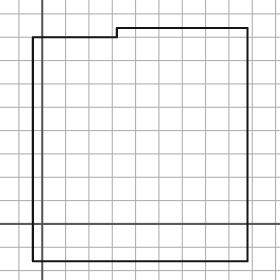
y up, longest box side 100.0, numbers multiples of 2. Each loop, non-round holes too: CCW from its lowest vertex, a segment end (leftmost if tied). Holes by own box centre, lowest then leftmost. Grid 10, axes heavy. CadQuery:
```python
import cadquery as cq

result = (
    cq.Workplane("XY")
    .moveTo(-4.0, -16.0)
    .lineTo(88.0, -16.0)
    .lineTo(88.0, 84.0)
    .lineTo(32.0, 84.0)
    .lineTo(32.0, 80.0)
    .lineTo(-4.0, 80.0)
    .close()
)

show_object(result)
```